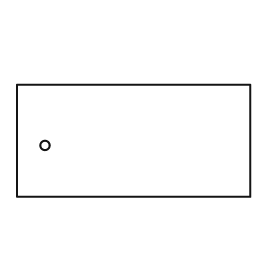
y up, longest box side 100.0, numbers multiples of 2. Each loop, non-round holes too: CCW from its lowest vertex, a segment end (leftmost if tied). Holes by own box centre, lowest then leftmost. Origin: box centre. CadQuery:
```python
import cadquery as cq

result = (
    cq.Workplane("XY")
    .moveTo(-50.0, -24.0)
    .lineTo(50.0, -24.0)
    .lineTo(50.0, 24.0)
    .lineTo(-50.0, 24.0)
    .close()
    .moveTo(-38.0, -2.0)
    .circle(2.0)
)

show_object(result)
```